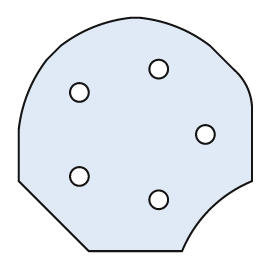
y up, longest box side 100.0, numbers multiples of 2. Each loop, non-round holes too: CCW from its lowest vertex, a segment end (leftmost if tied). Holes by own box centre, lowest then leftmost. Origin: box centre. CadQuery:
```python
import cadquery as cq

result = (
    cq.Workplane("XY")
    .moveTo(-20.0, -50.0)
    .lineTo(20.0, -50.0)
    .threePointArc((32.0, -32.0), (50.0, -20.0))
    .lineTo(50.0, 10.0)
    .threePointArc((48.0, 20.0), (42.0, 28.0))
    .lineTo(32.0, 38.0)
    .threePointArc((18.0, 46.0), (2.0, 50.0))
    .lineTo(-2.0, 50.0)
    .threePointArc((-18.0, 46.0), (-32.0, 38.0))
    .lineTo(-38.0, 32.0)
    .threePointArc((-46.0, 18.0), (-50.0, 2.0))
    .lineTo(-50.0, -20.0)
    .close()
    .moveTo(10.0, -28.0)
    .circle(4.0)
    .moveTo(-24.0, -18.0)
    .circle(4.0)
    .moveTo(30.0, 0.0)
    .circle(4.0)
    .moveTo(-24.0, 18.0)
    .circle(4.0)
    .moveTo(10.0, 28.0)
    .circle(4.0)
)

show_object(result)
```